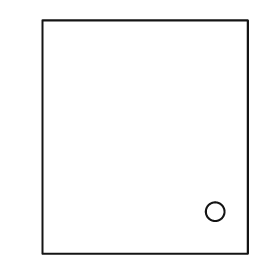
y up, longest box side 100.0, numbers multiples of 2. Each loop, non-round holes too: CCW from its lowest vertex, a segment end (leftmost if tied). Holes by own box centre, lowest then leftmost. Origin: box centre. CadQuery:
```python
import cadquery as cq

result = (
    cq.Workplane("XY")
    .moveTo(-44.0, -50.0)
    .lineTo(44.0, -50.0)
    .lineTo(44.0, 50.0)
    .lineTo(-44.0, 50.0)
    .close()
    .moveTo(30.0, -32.0)
    .circle(4.0)
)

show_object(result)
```